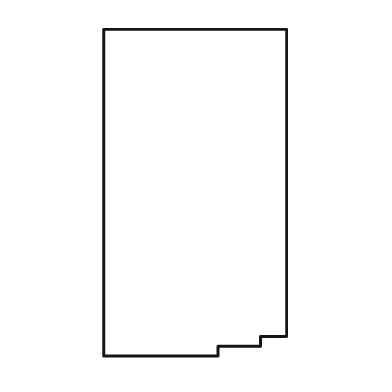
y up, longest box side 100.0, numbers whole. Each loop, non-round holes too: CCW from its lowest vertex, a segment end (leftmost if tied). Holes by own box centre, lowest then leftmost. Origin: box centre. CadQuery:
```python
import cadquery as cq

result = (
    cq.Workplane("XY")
    .moveTo(-28.0, -50.0)
    .lineTo(7.0, -50.0)
    .lineTo(7.0, -47.0)
    .lineTo(20.0, -47.0)
    .lineTo(20.0, -44.0)
    .lineTo(28.0, -44.0)
    .lineTo(28.0, 50.0)
    .lineTo(-28.0, 50.0)
    .close()
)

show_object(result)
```